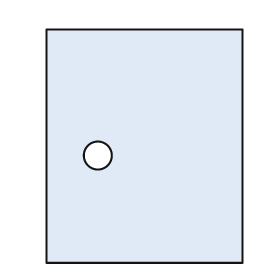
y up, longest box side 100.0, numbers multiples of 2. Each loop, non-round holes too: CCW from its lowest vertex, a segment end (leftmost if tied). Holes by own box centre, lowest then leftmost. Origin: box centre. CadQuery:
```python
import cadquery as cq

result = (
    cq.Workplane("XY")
    .moveTo(-42.0, -50.0)
    .lineTo(42.0, -50.0)
    .lineTo(42.0, 50.0)
    .lineTo(-42.0, 50.0)
    .close()
    .moveTo(-20.0, -4.0)
    .circle(6.0)
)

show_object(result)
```